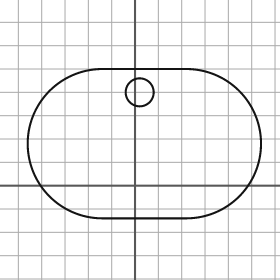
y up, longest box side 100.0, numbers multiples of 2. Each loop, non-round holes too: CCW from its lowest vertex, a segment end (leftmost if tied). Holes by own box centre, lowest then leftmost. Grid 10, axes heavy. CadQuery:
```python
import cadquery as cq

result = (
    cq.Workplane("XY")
    .moveTo(-14.0, -14.0)
    .lineTo(22.0, -14.0)
    .threePointArc((54.0, 18.0), (22.0, 50.0))
    .lineTo(-14.0, 50.0)
    .threePointArc((-46.0, 18.0), (-14.0, -14.0))
    .close()
    .moveTo(2.0, 40.0)
    .circle(6.0)
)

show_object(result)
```